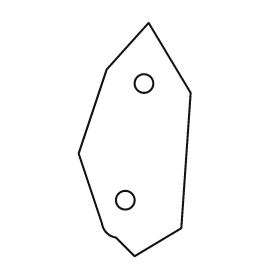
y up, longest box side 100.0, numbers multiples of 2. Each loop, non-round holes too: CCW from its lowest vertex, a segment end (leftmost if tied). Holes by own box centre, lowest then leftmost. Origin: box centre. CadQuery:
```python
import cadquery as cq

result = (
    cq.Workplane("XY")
    .moveTo(0.0, -50.0)
    .lineTo(20.0, -38.0)
    .lineTo(24.0, 20.0)
    .lineTo(6.0, 50.0)
    .lineTo(-12.0, 30.0)
    .lineTo(-24.0, -6.0)
    .lineTo(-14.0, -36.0)
    .threePointArc((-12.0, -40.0), (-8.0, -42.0))
    .close()
    .moveTo(-4.0, -26.0)
    .circle(4.0)
    .moveTo(4.0, 24.0)
    .circle(4.0)
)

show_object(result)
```